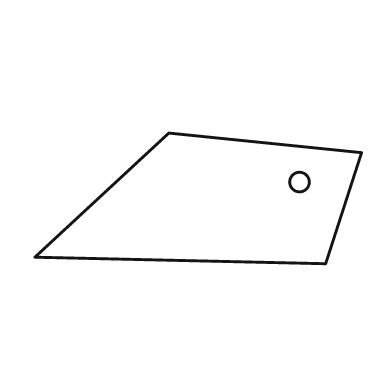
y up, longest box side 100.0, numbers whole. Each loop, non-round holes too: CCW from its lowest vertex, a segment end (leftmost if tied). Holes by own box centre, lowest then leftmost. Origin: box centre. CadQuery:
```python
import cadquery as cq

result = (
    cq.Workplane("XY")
    .moveTo(39.0, -20.0)
    .lineTo(50.0, 14.0)
    .lineTo(-9.0, 20.0)
    .lineTo(-50.0, -18.0)
    .close()
    .moveTo(31.0, 5.0)
    .circle(3.0)
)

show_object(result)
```